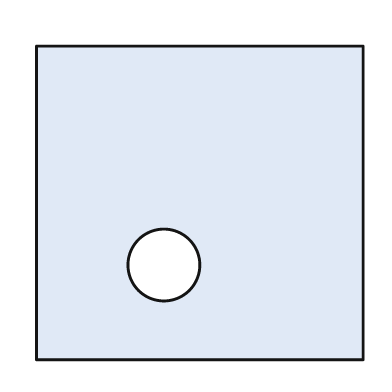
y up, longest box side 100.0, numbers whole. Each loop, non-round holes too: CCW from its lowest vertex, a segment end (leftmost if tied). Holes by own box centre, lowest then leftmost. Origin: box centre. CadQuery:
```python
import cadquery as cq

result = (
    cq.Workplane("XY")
    .moveTo(-50.0, -48.0)
    .lineTo(50.0, -48.0)
    .lineTo(50.0, 48.0)
    .lineTo(-50.0, 48.0)
    .close()
    .moveTo(-11.0, -19.0)
    .circle(11.0)
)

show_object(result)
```